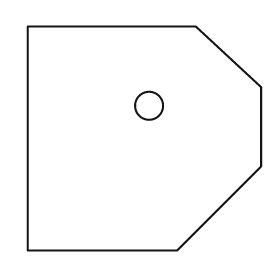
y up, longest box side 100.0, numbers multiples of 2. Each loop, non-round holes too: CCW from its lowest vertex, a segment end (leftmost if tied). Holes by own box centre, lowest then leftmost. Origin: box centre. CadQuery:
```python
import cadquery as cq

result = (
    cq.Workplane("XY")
    .moveTo(-50.0, -48.0)
    .lineTo(14.0, -48.0)
    .lineTo(50.0, -12.0)
    .lineTo(50.0, 22.0)
    .lineTo(22.0, 48.0)
    .lineTo(-50.0, 48.0)
    .close()
    .moveTo(2.0, 14.0)
    .circle(6.0)
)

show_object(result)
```